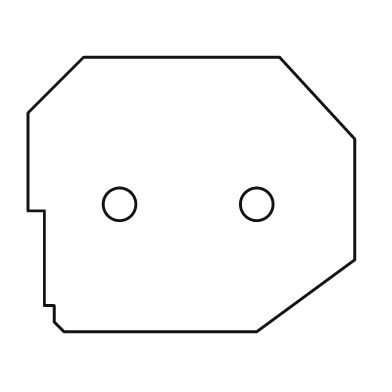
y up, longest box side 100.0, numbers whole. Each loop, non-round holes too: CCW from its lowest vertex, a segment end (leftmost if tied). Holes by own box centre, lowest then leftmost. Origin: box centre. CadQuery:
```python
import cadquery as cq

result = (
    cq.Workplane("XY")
    .moveTo(-39.0, -42.0)
    .lineTo(20.0, -42.0)
    .lineTo(50.0, -20.0)
    .lineTo(50.0, 17.0)
    .lineTo(27.0, 42.0)
    .lineTo(-33.0, 42.0)
    .lineTo(-50.0, 25.0)
    .lineTo(-50.0, -5.0)
    .lineTo(-45.0, -5.0)
    .lineTo(-45.0, -34.0)
    .lineTo(-42.0, -34.0)
    .lineTo(-42.0, -39.0)
    .close()
    .moveTo(-22.0, -3.0)
    .circle(5.0)
    .moveTo(20.0, -3.0)
    .circle(5.0)
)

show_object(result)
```